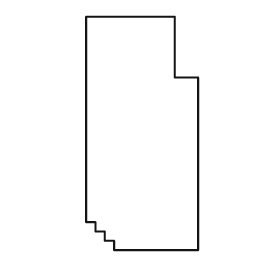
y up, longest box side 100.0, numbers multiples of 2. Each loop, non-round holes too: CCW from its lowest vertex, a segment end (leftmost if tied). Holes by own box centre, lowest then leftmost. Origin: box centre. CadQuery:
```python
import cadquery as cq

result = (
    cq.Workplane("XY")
    .moveTo(-12.0, -50.0)
    .lineTo(24.0, -50.0)
    .lineTo(24.0, 24.0)
    .lineTo(14.0, 24.0)
    .lineTo(14.0, 50.0)
    .lineTo(-24.0, 50.0)
    .lineTo(-24.0, -38.0)
    .lineTo(-20.0, -38.0)
    .lineTo(-20.0, -42.0)
    .lineTo(-16.0, -42.0)
    .lineTo(-16.0, -46.0)
    .lineTo(-12.0, -46.0)
    .close()
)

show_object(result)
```